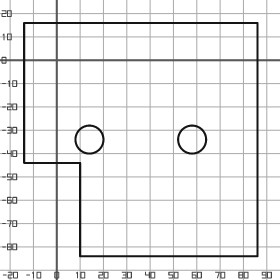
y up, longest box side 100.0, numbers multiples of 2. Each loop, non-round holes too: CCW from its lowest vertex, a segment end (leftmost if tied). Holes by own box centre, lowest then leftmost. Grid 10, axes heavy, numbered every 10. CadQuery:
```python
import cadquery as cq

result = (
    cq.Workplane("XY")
    .moveTo(10.0, -84.0)
    .lineTo(86.0, -84.0)
    .lineTo(86.0, 16.0)
    .lineTo(-14.0, 16.0)
    .lineTo(-14.0, -44.0)
    .lineTo(10.0, -44.0)
    .close()
    .moveTo(14.0, -34.0)
    .circle(6.0)
    .moveTo(58.0, -34.0)
    .circle(6.0)
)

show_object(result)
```